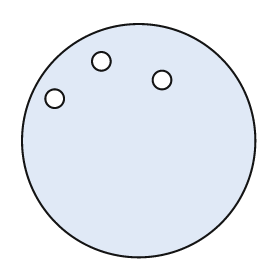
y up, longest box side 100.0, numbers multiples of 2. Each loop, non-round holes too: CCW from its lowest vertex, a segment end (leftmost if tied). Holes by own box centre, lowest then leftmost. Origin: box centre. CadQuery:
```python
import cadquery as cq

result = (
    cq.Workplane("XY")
    .moveTo(0.0, 0.0)
    .circle(50.0)
    .moveTo(-36.0, 18.0)
    .circle(4.0)
    .moveTo(10.0, 26.0)
    .circle(4.0)
    .moveTo(-16.0, 34.0)
    .circle(4.0)
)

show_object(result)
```